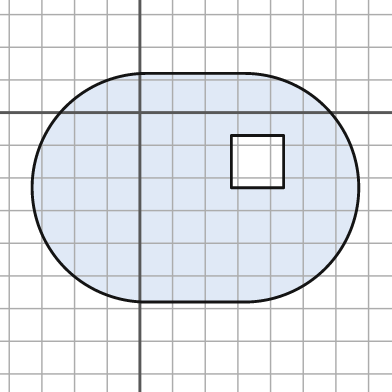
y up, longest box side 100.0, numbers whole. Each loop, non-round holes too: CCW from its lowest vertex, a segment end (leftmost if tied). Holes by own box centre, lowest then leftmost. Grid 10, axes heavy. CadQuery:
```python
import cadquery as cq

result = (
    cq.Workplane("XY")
    .moveTo(2.0, -58.0)
    .lineTo(32.0, -58.0)
    .threePointArc((67.0, -23.0), (32.0, 12.0))
    .lineTo(2.0, 12.0)
    .threePointArc((-33.0, -23.0), (2.0, -58.0))
    .close()
    .moveTo(28.0, -23.0)
    .lineTo(44.0, -23.0)
    .lineTo(44.0, -7.0)
    .lineTo(28.0, -7.0)
    .close()
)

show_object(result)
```